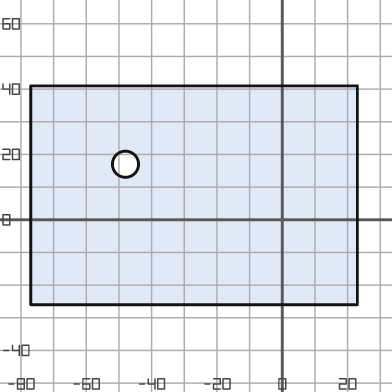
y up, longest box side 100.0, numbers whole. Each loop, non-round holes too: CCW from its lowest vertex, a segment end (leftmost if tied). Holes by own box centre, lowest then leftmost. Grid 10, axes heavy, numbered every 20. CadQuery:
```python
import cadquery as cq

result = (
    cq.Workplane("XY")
    .moveTo(-77.0, -26.0)
    .lineTo(23.0, -26.0)
    .lineTo(23.0, 41.0)
    .lineTo(-77.0, 41.0)
    .close()
    .moveTo(-48.0, 17.0)
    .circle(4.0)
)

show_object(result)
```